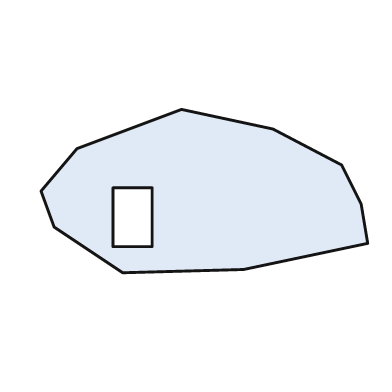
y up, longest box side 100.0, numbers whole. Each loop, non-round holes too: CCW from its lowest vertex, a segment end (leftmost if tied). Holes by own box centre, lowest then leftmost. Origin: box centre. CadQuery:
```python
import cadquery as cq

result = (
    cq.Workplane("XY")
    .moveTo(-25.0, -25.0)
    .lineTo(12.0, -24.0)
    .lineTo(50.0, -16.0)
    .lineTo(48.0, -4.0)
    .lineTo(42.0, 8.0)
    .lineTo(21.0, 19.0)
    .lineTo(-7.0, 25.0)
    .lineTo(-39.0, 13.0)
    .lineTo(-50.0, 0.0)
    .lineTo(-46.0, -11.0)
    .close()
    .moveTo(-28.0, -17.0)
    .lineTo(-16.0, -17.0)
    .lineTo(-16.0, 1.0)
    .lineTo(-28.0, 1.0)
    .close()
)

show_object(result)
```